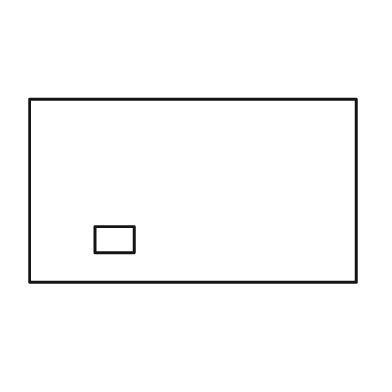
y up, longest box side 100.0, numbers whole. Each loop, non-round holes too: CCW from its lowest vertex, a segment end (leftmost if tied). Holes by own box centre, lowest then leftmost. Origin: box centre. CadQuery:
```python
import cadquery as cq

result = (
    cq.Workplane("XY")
    .moveTo(-50.0, -28.0)
    .lineTo(50.0, -28.0)
    .lineTo(50.0, 28.0)
    .lineTo(-50.0, 28.0)
    .close()
    .moveTo(-30.0, -19.0)
    .lineTo(-18.0, -19.0)
    .lineTo(-18.0, -11.0)
    .lineTo(-30.0, -11.0)
    .close()
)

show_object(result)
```